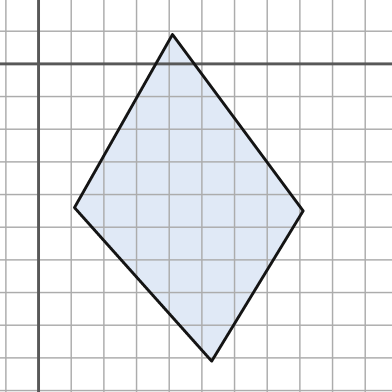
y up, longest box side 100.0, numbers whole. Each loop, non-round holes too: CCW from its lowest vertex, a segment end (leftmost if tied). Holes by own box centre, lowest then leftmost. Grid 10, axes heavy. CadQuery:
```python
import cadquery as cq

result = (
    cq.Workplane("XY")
    .moveTo(53.0, -91.0)
    .lineTo(81.0, -45.0)
    .lineTo(41.0, 9.0)
    .lineTo(11.0, -44.0)
    .close()
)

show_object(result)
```